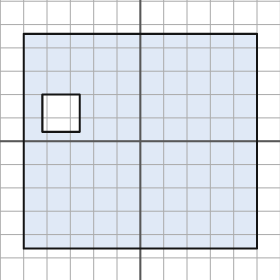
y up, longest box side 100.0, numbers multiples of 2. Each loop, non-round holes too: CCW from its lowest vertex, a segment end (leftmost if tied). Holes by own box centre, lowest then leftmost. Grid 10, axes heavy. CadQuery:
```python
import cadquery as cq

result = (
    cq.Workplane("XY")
    .moveTo(-50.0, -46.0)
    .lineTo(50.0, -46.0)
    .lineTo(50.0, 46.0)
    .lineTo(-50.0, 46.0)
    .close()
    .moveTo(-42.0, 4.0)
    .lineTo(-26.0, 4.0)
    .lineTo(-26.0, 20.0)
    .lineTo(-42.0, 20.0)
    .close()
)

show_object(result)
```